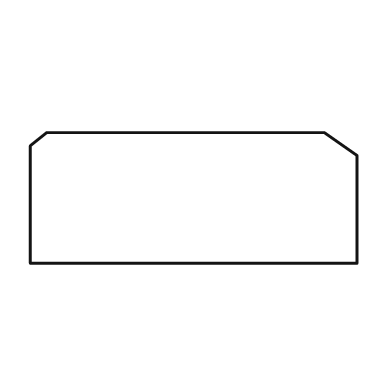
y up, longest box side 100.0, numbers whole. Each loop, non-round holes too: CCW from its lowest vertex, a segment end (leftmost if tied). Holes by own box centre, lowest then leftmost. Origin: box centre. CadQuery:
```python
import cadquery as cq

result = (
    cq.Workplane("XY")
    .moveTo(-50.0, -20.0)
    .lineTo(50.0, -20.0)
    .lineTo(50.0, 13.0)
    .lineTo(40.0, 20.0)
    .lineTo(-45.0, 20.0)
    .lineTo(-50.0, 16.0)
    .close()
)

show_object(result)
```